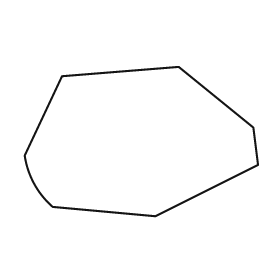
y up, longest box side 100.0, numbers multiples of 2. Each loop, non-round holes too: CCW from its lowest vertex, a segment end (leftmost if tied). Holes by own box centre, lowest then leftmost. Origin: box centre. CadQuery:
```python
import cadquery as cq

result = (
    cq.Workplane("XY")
    .moveTo(6.0, -32.0)
    .lineTo(50.0, -10.0)
    .lineTo(48.0, 6.0)
    .lineTo(16.0, 32.0)
    .lineTo(-34.0, 28.0)
    .lineTo(-50.0, -6.0)
    .threePointArc((-46.0, -18.0), (-38.0, -28.0))
    .close()
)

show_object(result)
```